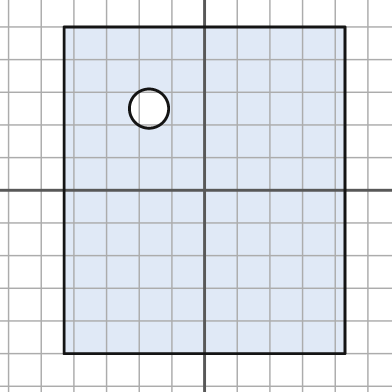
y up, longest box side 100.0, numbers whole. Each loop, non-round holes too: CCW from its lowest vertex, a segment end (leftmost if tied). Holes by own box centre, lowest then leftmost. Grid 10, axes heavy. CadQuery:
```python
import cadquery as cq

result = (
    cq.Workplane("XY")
    .moveTo(-43.0, -50.0)
    .lineTo(43.0, -50.0)
    .lineTo(43.0, 50.0)
    .lineTo(-43.0, 50.0)
    .close()
    .moveTo(-17.0, 25.0)
    .circle(6.0)
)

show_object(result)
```